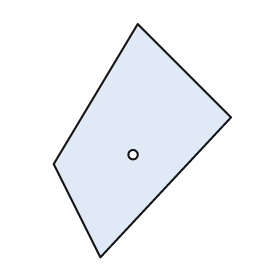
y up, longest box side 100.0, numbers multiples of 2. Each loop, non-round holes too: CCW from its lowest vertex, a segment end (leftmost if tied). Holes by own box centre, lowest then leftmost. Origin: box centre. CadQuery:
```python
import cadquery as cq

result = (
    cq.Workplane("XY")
    .moveTo(-18.0, -50.0)
    .lineTo(38.0, 10.0)
    .lineTo(-2.0, 50.0)
    .lineTo(-38.0, -10.0)
    .close()
    .moveTo(-4.0, -6.0)
    .circle(2.0)
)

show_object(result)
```